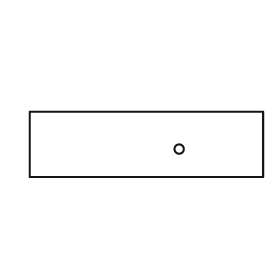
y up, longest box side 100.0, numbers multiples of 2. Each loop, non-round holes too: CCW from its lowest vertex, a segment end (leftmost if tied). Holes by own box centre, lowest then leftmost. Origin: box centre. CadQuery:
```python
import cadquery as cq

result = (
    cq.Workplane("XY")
    .moveTo(-50.0, -14.0)
    .lineTo(50.0, -14.0)
    .lineTo(50.0, 14.0)
    .lineTo(-50.0, 14.0)
    .close()
    .moveTo(14.0, -2.0)
    .circle(2.0)
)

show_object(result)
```